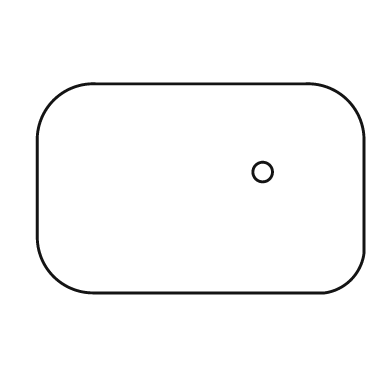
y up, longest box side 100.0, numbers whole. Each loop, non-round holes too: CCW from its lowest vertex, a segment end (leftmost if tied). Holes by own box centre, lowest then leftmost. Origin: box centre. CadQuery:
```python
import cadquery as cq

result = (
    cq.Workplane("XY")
    .moveTo(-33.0, -32.0)
    .lineTo(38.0, -32.0)
    .threePointArc((46.0, -28.0), (50.0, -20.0))
    .lineTo(50.0, 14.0)
    .threePointArc((45.0, 27.0), (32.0, 32.0))
    .lineTo(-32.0, 32.0)
    .threePointArc((-45.0, 27.0), (-50.0, 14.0))
    .lineTo(-50.0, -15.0)
    .threePointArc((-45.0, -27.0), (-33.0, -32.0))
    .close()
    .moveTo(19.0, 5.0)
    .circle(3.0)
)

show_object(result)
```